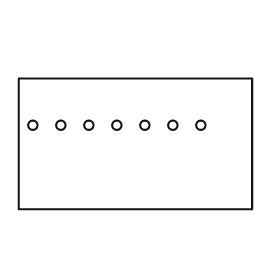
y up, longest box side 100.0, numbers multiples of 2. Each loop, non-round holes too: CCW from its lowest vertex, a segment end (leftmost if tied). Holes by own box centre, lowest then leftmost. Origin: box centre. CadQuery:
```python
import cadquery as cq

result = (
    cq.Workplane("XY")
    .moveTo(-50.0, -28.0)
    .lineTo(50.0, -28.0)
    .lineTo(50.0, 28.0)
    .lineTo(-50.0, 28.0)
    .close()
    .moveTo(-44.0, 8.0)
    .circle(2.0)
    .moveTo(-32.0, 8.0)
    .circle(2.0)
    .moveTo(-20.0, 8.0)
    .circle(2.0)
    .moveTo(-8.0, 8.0)
    .circle(2.0)
    .moveTo(4.0, 8.0)
    .circle(2.0)
    .moveTo(16.0, 8.0)
    .circle(2.0)
    .moveTo(28.0, 8.0)
    .circle(2.0)
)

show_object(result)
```